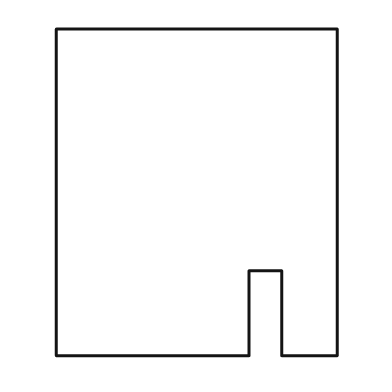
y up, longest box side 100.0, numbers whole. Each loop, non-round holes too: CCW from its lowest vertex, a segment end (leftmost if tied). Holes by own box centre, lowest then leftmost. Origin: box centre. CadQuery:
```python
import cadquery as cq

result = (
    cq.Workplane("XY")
    .moveTo(-43.0, -50.0)
    .lineTo(16.0, -50.0)
    .lineTo(16.0, -24.0)
    .lineTo(26.0, -24.0)
    .lineTo(26.0, -50.0)
    .lineTo(43.0, -50.0)
    .lineTo(43.0, 50.0)
    .lineTo(-43.0, 50.0)
    .close()
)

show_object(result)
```